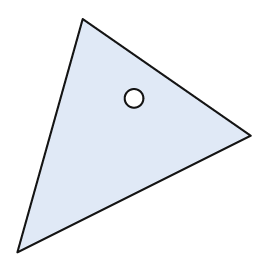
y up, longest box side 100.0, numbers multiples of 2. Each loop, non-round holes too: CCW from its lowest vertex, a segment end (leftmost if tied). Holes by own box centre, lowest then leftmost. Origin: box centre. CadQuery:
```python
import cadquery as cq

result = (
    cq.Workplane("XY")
    .moveTo(-50.0, -50.0)
    .lineTo(50.0, 0.0)
    .lineTo(-22.0, 50.0)
    .close()
    .moveTo(0.0, 16.0)
    .circle(4.0)
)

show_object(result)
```